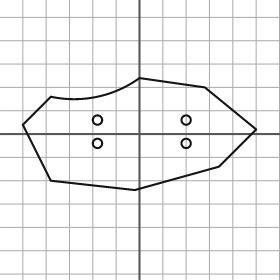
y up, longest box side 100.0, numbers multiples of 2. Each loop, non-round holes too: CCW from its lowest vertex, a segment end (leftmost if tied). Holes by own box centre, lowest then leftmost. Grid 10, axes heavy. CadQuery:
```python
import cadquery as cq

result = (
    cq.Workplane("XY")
    .moveTo(-2.0, -24.0)
    .lineTo(34.0, -14.0)
    .lineTo(50.0, 2.0)
    .lineTo(28.0, 20.0)
    .lineTo(0.0, 24.0)
    .threePointArc((-18.0, 16.0), (-38.0, 16.0))
    .lineTo(-50.0, 4.0)
    .lineTo(-38.0, -20.0)
    .close()
    .moveTo(-18.0, -4.0)
    .circle(2.0)
    .moveTo(20.0, -4.0)
    .circle(2.0)
    .moveTo(-18.0, 6.0)
    .circle(2.0)
    .moveTo(20.0, 6.0)
    .circle(2.0)
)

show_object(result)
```